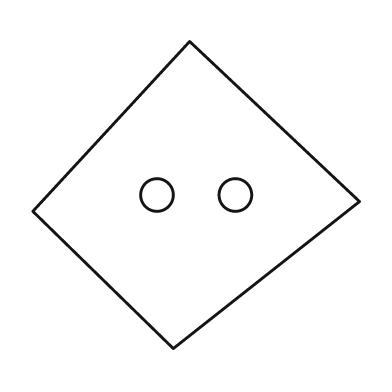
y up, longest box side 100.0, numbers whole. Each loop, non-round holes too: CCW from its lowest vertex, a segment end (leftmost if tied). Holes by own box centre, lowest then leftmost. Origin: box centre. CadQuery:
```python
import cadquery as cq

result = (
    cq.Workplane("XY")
    .moveTo(-7.0, -47.0)
    .lineTo(50.0, -2.0)
    .lineTo(-2.0, 47.0)
    .lineTo(-50.0, -5.0)
    .close()
    .moveTo(-12.0, 0.0)
    .circle(5.0)
    .moveTo(12.0, 0.0)
    .circle(5.0)
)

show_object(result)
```